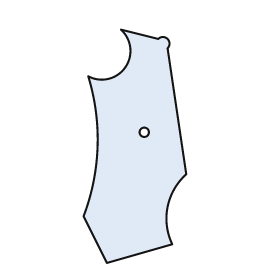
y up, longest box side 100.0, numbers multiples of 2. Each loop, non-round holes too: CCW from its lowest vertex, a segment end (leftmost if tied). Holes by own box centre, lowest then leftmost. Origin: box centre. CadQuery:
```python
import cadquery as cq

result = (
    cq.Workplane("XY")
    .moveTo(-12.0, -50.0)
    .lineTo(16.0, -42.0)
    .threePointArc((14.0, -26.0), (22.0, -12.0))
    .lineTo(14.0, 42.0)
    .threePointArc((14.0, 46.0), (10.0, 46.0))
    .lineTo(-6.0, 50.0)
    .threePointArc((-4.0, 34.0), (-20.0, 30.0))
    .threePointArc((-16.0, 0.0), (-22.0, -30.0))
    .close()
    .moveTo(4.0, 6.0)
    .circle(2.0)
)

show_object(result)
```